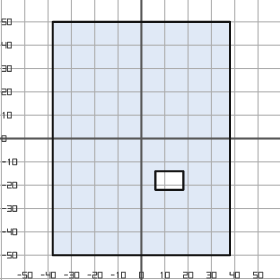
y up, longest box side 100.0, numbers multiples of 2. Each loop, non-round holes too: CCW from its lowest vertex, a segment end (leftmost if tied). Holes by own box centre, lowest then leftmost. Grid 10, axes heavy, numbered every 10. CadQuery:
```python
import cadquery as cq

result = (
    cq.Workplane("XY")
    .moveTo(-38.0, -50.0)
    .lineTo(38.0, -50.0)
    .lineTo(38.0, 50.0)
    .lineTo(-38.0, 50.0)
    .close()
    .moveTo(6.0, -22.0)
    .lineTo(18.0, -22.0)
    .lineTo(18.0, -14.0)
    .lineTo(6.0, -14.0)
    .close()
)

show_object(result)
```